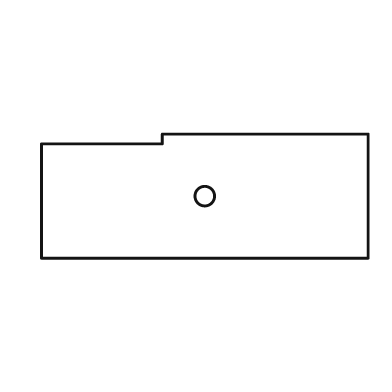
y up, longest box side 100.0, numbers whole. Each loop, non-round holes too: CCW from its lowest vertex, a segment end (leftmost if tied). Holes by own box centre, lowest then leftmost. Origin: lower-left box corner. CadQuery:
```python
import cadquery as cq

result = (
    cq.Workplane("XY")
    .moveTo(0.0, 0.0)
    .lineTo(100.0, 0.0)
    .lineTo(100.0, 38.0)
    .lineTo(37.0, 38.0)
    .lineTo(37.0, 35.0)
    .lineTo(0.0, 35.0)
    .close()
    .moveTo(50.0, 19.0)
    .circle(3.0)
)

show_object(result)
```